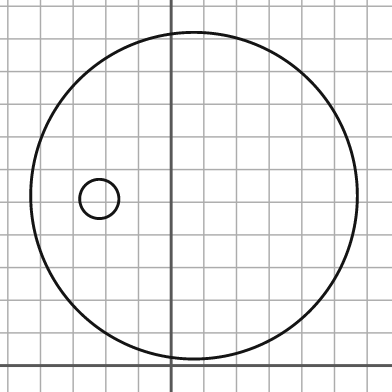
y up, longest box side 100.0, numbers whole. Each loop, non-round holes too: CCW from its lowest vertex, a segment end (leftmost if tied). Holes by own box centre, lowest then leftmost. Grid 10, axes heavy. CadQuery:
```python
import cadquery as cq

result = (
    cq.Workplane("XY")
    .moveTo(7.0, 52.0)
    .circle(50.0)
    .moveTo(-22.0, 51.0)
    .circle(6.0)
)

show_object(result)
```